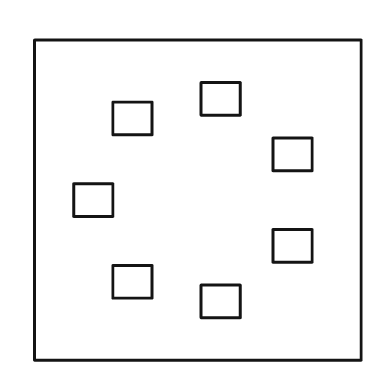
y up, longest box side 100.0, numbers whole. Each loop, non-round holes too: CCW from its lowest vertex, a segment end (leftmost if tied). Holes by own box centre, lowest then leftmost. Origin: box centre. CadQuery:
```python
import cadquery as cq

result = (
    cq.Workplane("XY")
    .moveTo(-50.0, -49.0)
    .lineTo(50.0, -49.0)
    .lineTo(50.0, 49.0)
    .lineTo(-50.0, 49.0)
    .close()
    .moveTo(1.0, -36.0)
    .lineTo(13.0, -36.0)
    .lineTo(13.0, -26.0)
    .lineTo(1.0, -26.0)
    .close()
    .moveTo(-26.0, -30.0)
    .lineTo(-14.0, -30.0)
    .lineTo(-14.0, -20.0)
    .lineTo(-26.0, -20.0)
    .close()
    .moveTo(23.0, -19.0)
    .lineTo(35.0, -19.0)
    .lineTo(35.0, -9.0)
    .lineTo(23.0, -9.0)
    .close()
    .moveTo(-38.0, -5.0)
    .lineTo(-26.0, -5.0)
    .lineTo(-26.0, 5.0)
    .lineTo(-38.0, 5.0)
    .close()
    .moveTo(23.0, 9.0)
    .lineTo(35.0, 9.0)
    .lineTo(35.0, 19.0)
    .lineTo(23.0, 19.0)
    .close()
    .moveTo(-26.0, 20.0)
    .lineTo(-14.0, 20.0)
    .lineTo(-14.0, 30.0)
    .lineTo(-26.0, 30.0)
    .close()
    .moveTo(1.0, 26.0)
    .lineTo(13.0, 26.0)
    .lineTo(13.0, 36.0)
    .lineTo(1.0, 36.0)
    .close()
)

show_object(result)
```